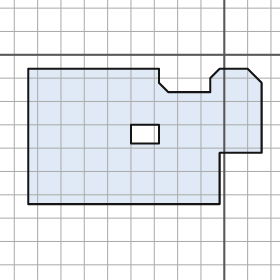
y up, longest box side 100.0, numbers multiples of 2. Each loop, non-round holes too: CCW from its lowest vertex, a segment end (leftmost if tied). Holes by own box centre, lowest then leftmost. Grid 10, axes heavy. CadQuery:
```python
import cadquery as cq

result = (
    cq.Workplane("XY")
    .moveTo(-84.0, -64.0)
    .lineTo(-2.0, -64.0)
    .lineTo(-2.0, -42.0)
    .lineTo(16.0, -42.0)
    .lineTo(16.0, -12.0)
    .lineTo(10.0, -6.0)
    .lineTo(-2.0, -6.0)
    .lineTo(-6.0, -10.0)
    .lineTo(-6.0, -16.0)
    .lineTo(-24.0, -16.0)
    .lineTo(-28.0, -12.0)
    .lineTo(-28.0, -6.0)
    .lineTo(-84.0, -6.0)
    .close()
    .moveTo(-40.0, -38.0)
    .lineTo(-28.0, -38.0)
    .lineTo(-28.0, -30.0)
    .lineTo(-40.0, -30.0)
    .close()
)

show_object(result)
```